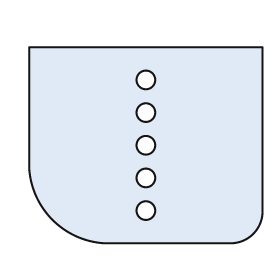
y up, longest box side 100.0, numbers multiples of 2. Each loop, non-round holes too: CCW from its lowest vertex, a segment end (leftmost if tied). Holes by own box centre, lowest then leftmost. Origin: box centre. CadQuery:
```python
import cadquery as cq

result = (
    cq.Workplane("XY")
    .moveTo(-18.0, -42.0)
    .lineTo(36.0, -42.0)
    .threePointArc((46.0, -38.0), (50.0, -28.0))
    .lineTo(50.0, 42.0)
    .lineTo(-50.0, 42.0)
    .lineTo(-50.0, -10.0)
    .threePointArc((-40.0, -32.0), (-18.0, -42.0))
    .close()
    .moveTo(0.0, -28.0)
    .circle(4.0)
    .moveTo(0.0, -14.0)
    .circle(4.0)
    .moveTo(0.0, 0.0)
    .circle(4.0)
    .moveTo(0.0, 14.0)
    .circle(4.0)
    .moveTo(0.0, 28.0)
    .circle(4.0)
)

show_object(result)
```